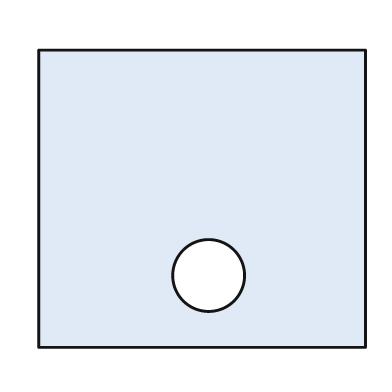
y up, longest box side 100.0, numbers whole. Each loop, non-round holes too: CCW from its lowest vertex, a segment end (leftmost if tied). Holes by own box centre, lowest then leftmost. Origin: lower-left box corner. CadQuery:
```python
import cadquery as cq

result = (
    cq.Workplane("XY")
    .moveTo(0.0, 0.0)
    .lineTo(100.0, 0.0)
    .lineTo(100.0, 91.0)
    .lineTo(0.0, 91.0)
    .close()
    .moveTo(52.0, 22.0)
    .circle(11.0)
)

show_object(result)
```